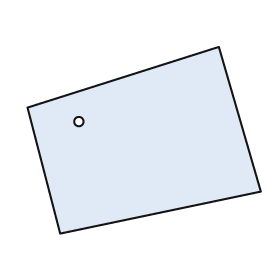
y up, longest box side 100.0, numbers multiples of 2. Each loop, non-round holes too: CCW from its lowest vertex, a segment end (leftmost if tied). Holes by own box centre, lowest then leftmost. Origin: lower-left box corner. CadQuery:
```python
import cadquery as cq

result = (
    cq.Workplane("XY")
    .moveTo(14.0, 0.0)
    .lineTo(100.0, 18.0)
    .lineTo(82.0, 80.0)
    .lineTo(0.0, 54.0)
    .close()
    .moveTo(22.0, 48.0)
    .circle(2.0)
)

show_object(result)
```